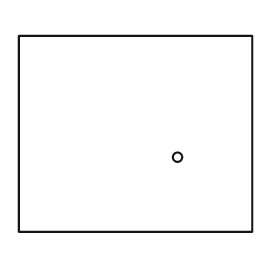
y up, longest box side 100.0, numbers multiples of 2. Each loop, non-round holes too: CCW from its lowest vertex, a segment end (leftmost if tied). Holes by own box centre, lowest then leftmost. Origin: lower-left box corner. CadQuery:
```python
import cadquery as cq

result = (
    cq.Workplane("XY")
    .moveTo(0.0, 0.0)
    .lineTo(100.0, 0.0)
    .lineTo(100.0, 84.0)
    .lineTo(0.0, 84.0)
    .close()
    .moveTo(68.0, 32.0)
    .circle(2.0)
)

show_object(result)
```